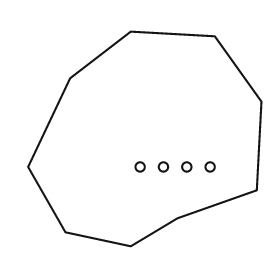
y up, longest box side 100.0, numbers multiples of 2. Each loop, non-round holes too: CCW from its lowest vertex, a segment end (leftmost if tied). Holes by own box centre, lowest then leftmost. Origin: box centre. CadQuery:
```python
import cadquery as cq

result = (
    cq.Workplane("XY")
    .moveTo(-6.0, -46.0)
    .lineTo(14.0, -34.0)
    .lineTo(48.0, -22.0)
    .lineTo(50.0, 16.0)
    .lineTo(30.0, 44.0)
    .lineTo(-6.0, 46.0)
    .lineTo(-32.0, 26.0)
    .lineTo(-50.0, -12.0)
    .lineTo(-34.0, -40.0)
    .close()
    .moveTo(-2.0, -12.0)
    .circle(2.0)
    .moveTo(8.0, -12.0)
    .circle(2.0)
    .moveTo(18.0, -12.0)
    .circle(2.0)
    .moveTo(28.0, -12.0)
    .circle(2.0)
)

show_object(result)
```